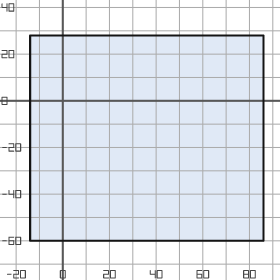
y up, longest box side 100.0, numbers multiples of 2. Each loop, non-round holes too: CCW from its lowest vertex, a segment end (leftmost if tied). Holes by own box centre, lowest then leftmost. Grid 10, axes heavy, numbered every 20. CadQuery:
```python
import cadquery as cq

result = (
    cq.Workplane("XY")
    .moveTo(-14.0, -60.0)
    .lineTo(86.0, -60.0)
    .lineTo(86.0, 28.0)
    .lineTo(-14.0, 28.0)
    .close()
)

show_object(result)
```